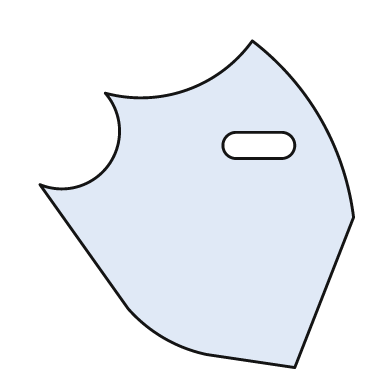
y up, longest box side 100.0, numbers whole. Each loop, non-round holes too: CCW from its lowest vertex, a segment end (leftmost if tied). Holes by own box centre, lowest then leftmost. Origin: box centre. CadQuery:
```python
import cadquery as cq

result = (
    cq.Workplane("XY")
    .moveTo(30.0, -50.0)
    .lineTo(48.0, -4.0)
    .threePointArc((38.0, 26.0), (17.0, 50.0))
    .threePointArc((-3.0, 35.0), (-28.0, 34.0))
    .threePointArc((-27.0, 12.0), (-48.0, 6.0))
    .lineTo(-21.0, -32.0)
    .threePointArc((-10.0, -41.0), (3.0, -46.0))
    .close()
    .moveTo(12.0, 14.0)
    .lineTo(26.0, 14.0)
    .threePointArc((30.0, 18.0), (26.0, 22.0))
    .lineTo(12.0, 22.0)
    .threePointArc((8.0, 18.0), (12.0, 14.0))
    .close()
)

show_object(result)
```